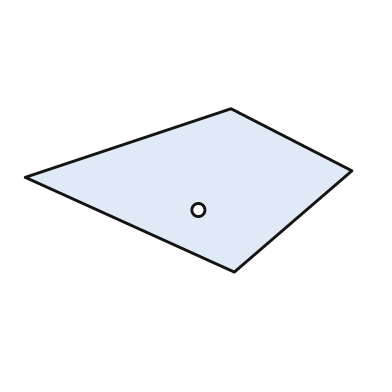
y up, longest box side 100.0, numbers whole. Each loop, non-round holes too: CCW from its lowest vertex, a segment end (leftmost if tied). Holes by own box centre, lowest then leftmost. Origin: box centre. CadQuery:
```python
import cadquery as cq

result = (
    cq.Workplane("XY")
    .moveTo(14.0, -25.0)
    .lineTo(50.0, 6.0)
    .lineTo(13.0, 25.0)
    .lineTo(-50.0, 4.0)
    .close()
    .moveTo(3.0, -6.0)
    .circle(2.0)
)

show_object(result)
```